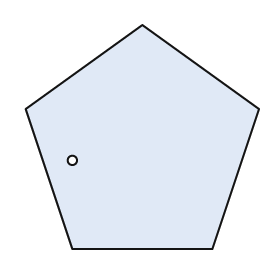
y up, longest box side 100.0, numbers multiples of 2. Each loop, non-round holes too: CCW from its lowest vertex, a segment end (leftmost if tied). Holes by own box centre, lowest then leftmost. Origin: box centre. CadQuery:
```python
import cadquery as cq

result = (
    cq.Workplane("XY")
    .moveTo(-30.0, -48.0)
    .lineTo(30.0, -48.0)
    .lineTo(50.0, 12.0)
    .lineTo(0.0, 48.0)
    .lineTo(-50.0, 12.0)
    .close()
    .moveTo(-30.0, -10.0)
    .circle(2.0)
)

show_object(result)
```